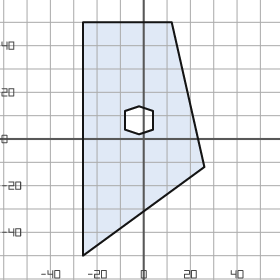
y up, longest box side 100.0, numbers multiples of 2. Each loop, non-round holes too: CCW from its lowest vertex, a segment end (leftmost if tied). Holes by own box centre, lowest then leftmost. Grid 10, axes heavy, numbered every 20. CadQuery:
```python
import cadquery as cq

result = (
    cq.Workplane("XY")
    .moveTo(-26.0, -50.0)
    .lineTo(26.0, -12.0)
    .lineTo(12.0, 50.0)
    .lineTo(-26.0, 50.0)
    .close()
    .moveTo(-2.0, 2.0)
    .lineTo(4.0, 4.0)
    .lineTo(4.0, 12.0)
    .lineTo(-2.0, 14.0)
    .lineTo(-8.0, 12.0)
    .lineTo(-8.0, 4.0)
    .close()
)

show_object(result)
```